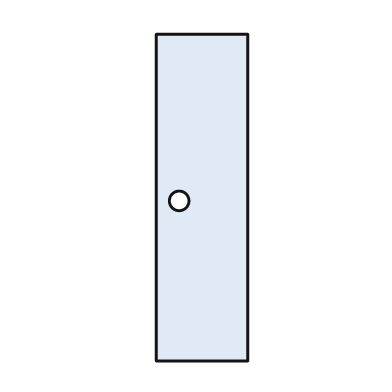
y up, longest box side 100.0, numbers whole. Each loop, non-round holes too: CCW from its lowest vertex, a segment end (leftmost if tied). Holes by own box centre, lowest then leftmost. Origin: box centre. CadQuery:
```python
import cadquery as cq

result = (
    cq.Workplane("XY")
    .moveTo(-14.0, -50.0)
    .lineTo(14.0, -50.0)
    .lineTo(14.0, 50.0)
    .lineTo(-14.0, 50.0)
    .close()
    .moveTo(-7.0, -1.0)
    .circle(3.0)
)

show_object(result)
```